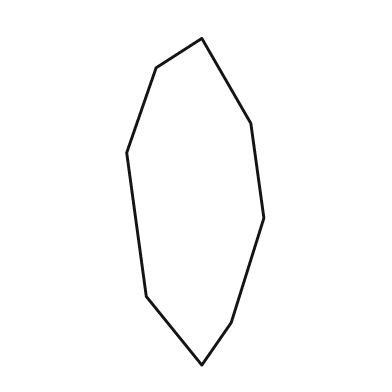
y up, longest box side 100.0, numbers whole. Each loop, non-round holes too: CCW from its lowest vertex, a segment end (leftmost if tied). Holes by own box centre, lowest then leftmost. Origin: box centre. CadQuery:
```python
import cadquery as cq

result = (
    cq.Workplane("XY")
    .moveTo(2.0, -50.0)
    .lineTo(11.0, -37.0)
    .lineTo(21.0, -5.0)
    .lineTo(17.0, 24.0)
    .lineTo(2.0, 50.0)
    .lineTo(-12.0, 41.0)
    .lineTo(-21.0, 15.0)
    .lineTo(-15.0, -29.0)
    .close()
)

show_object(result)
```